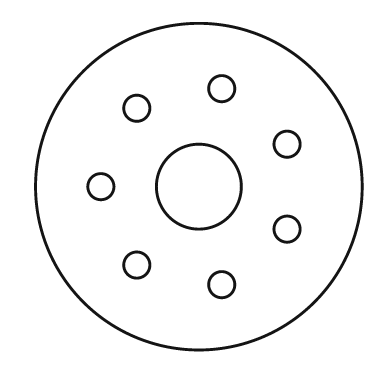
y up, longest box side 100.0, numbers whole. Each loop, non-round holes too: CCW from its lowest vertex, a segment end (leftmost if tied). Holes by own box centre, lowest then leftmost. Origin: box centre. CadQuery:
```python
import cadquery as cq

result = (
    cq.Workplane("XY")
    .moveTo(0.0, 0.0)
    .circle(50.0)
    .moveTo(7.0, -30.0)
    .circle(4.0)
    .moveTo(-19.0, -24.0)
    .circle(4.0)
    .moveTo(27.0, -13.0)
    .circle(4.0)
    .moveTo(-30.0, 0.0)
    .circle(4.0)
    .moveTo(0.0, 0.0)
    .circle(13.0)
    .moveTo(27.0, 13.0)
    .circle(4.0)
    .moveTo(-19.0, 24.0)
    .circle(4.0)
    .moveTo(7.0, 30.0)
    .circle(4.0)
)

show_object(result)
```